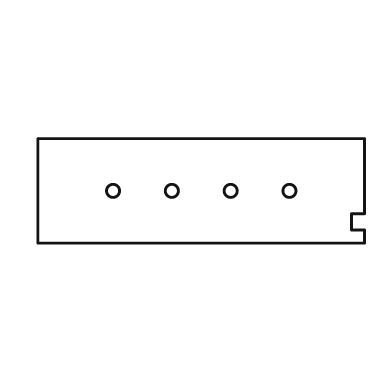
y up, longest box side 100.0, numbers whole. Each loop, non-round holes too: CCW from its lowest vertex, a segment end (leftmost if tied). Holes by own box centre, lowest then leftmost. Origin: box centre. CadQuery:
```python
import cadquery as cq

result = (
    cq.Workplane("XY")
    .moveTo(-50.0, -16.0)
    .lineTo(50.0, -16.0)
    .lineTo(50.0, -12.0)
    .lineTo(46.0, -12.0)
    .lineTo(46.0, -7.0)
    .lineTo(50.0, -7.0)
    .lineTo(50.0, 16.0)
    .lineTo(-50.0, 16.0)
    .close()
    .moveTo(-27.0, 0.0)
    .circle(2.0)
    .moveTo(-9.0, 0.0)
    .circle(2.0)
    .moveTo(9.0, 0.0)
    .circle(2.0)
    .moveTo(27.0, 0.0)
    .circle(2.0)
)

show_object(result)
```